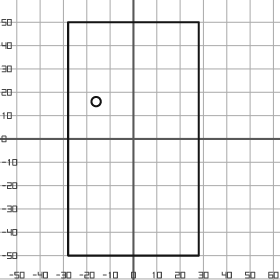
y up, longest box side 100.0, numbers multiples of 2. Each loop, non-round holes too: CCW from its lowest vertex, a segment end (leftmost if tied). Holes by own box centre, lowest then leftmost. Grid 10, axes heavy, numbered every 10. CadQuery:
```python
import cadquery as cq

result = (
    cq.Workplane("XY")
    .moveTo(-28.0, -50.0)
    .lineTo(28.0, -50.0)
    .lineTo(28.0, 50.0)
    .lineTo(-28.0, 50.0)
    .close()
    .moveTo(-16.0, 16.0)
    .circle(2.0)
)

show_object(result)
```